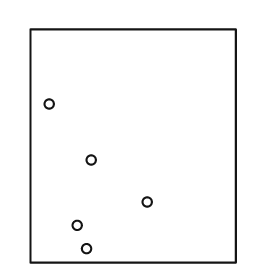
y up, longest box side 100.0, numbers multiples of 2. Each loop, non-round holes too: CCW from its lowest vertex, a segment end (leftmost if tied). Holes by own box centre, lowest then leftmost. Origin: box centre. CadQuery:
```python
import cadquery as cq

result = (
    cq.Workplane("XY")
    .moveTo(-44.0, -50.0)
    .lineTo(44.0, -50.0)
    .lineTo(44.0, 50.0)
    .lineTo(-44.0, 50.0)
    .close()
    .moveTo(-20.0, -44.0)
    .circle(2.0)
    .moveTo(-24.0, -34.0)
    .circle(2.0)
    .moveTo(6.0, -24.0)
    .circle(2.0)
    .moveTo(-18.0, -6.0)
    .circle(2.0)
    .moveTo(-36.0, 18.0)
    .circle(2.0)
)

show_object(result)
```